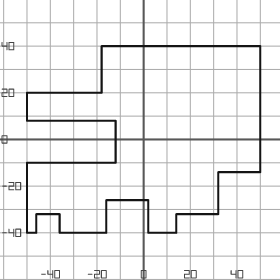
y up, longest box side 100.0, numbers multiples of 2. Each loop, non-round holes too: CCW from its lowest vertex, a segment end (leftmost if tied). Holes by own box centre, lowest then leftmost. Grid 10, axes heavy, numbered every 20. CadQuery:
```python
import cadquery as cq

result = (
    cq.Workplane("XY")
    .moveTo(-50.0, -40.0)
    .lineTo(-46.0, -40.0)
    .lineTo(-46.0, -32.0)
    .lineTo(-36.0, -32.0)
    .lineTo(-36.0, -40.0)
    .lineTo(-16.0, -40.0)
    .lineTo(-16.0, -26.0)
    .lineTo(2.0, -26.0)
    .lineTo(2.0, -40.0)
    .lineTo(14.0, -40.0)
    .lineTo(14.0, -32.0)
    .lineTo(32.0, -32.0)
    .lineTo(32.0, -14.0)
    .lineTo(50.0, -14.0)
    .lineTo(50.0, 40.0)
    .lineTo(-18.0, 40.0)
    .lineTo(-18.0, 20.0)
    .lineTo(-50.0, 20.0)
    .lineTo(-50.0, 8.0)
    .lineTo(-12.0, 8.0)
    .lineTo(-12.0, -10.0)
    .lineTo(-50.0, -10.0)
    .close()
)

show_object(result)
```